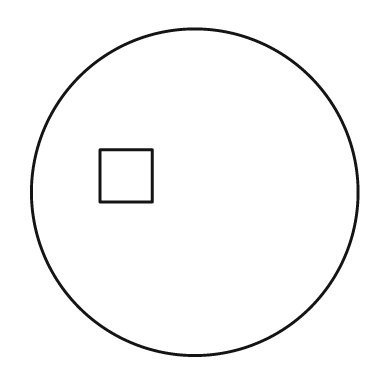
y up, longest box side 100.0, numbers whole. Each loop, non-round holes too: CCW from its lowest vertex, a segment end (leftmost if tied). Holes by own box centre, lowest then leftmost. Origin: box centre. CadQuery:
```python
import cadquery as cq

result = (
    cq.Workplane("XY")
    .moveTo(0.0, 0.0)
    .circle(50.0)
    .moveTo(-29.0, -3.0)
    .lineTo(-13.0, -3.0)
    .lineTo(-13.0, 13.0)
    .lineTo(-29.0, 13.0)
    .close()
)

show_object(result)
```